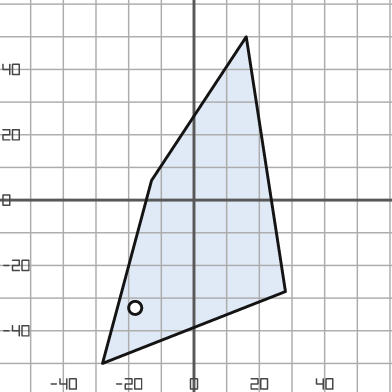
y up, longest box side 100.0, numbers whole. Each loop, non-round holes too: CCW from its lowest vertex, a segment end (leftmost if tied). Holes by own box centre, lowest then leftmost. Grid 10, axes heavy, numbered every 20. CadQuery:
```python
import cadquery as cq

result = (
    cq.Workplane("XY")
    .moveTo(-28.0, -50.0)
    .lineTo(28.0, -28.0)
    .lineTo(16.0, 50.0)
    .lineTo(-13.0, 6.0)
    .close()
    .moveTo(-18.0, -33.0)
    .circle(2.0)
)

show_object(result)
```